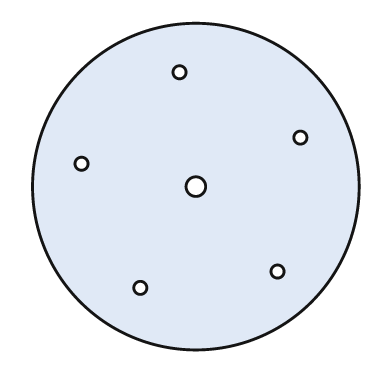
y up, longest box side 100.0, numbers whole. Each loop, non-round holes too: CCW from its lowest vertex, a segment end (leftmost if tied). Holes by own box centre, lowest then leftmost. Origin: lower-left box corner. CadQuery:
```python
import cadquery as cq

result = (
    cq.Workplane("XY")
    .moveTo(50.0, 50.0)
    .circle(50.0)
    .moveTo(33.0, 19.0)
    .circle(2.0)
    .moveTo(75.0, 24.0)
    .circle(2.0)
    .moveTo(50.0, 50.0)
    .circle(3.0)
    .moveTo(15.0, 57.0)
    .circle(2.0)
    .moveTo(82.0, 65.0)
    .circle(2.0)
    .moveTo(45.0, 85.0)
    .circle(2.0)
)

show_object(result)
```